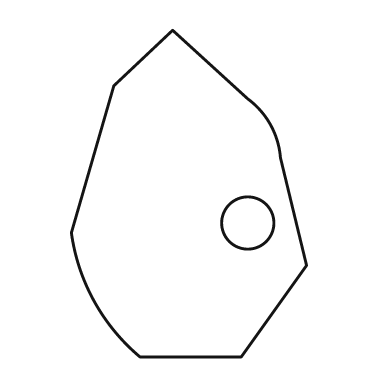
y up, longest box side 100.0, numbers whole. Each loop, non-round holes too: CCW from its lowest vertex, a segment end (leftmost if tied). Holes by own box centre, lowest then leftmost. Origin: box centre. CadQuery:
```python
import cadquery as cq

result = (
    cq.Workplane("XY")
    .moveTo(-15.0, -50.0)
    .lineTo(16.0, -50.0)
    .lineTo(36.0, -22.0)
    .lineTo(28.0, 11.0)
    .threePointArc((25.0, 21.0), (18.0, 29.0))
    .lineTo(-5.0, 50.0)
    .lineTo(-23.0, 33.0)
    .lineTo(-36.0, -12.0)
    .threePointArc((-29.0, -33.0), (-15.0, -50.0))
    .close()
    .moveTo(18.0, -9.0)
    .circle(8.0)
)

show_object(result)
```